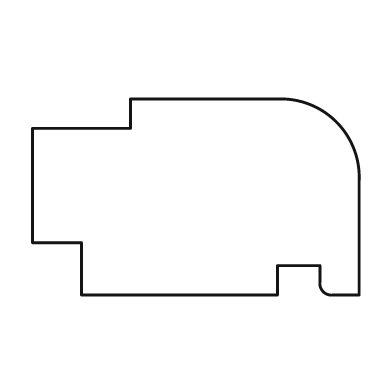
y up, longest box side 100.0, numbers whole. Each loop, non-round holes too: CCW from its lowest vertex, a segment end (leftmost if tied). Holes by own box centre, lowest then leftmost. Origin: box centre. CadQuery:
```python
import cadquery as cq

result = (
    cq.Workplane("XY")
    .moveTo(-35.0, -30.0)
    .lineTo(25.0, -30.0)
    .lineTo(25.0, -21.0)
    .lineTo(38.0, -21.0)
    .lineTo(38.0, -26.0)
    .threePointArc((39.0, -29.0), (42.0, -30.0))
    .lineTo(50.0, -30.0)
    .lineTo(50.0, 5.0)
    .threePointArc((43.0, 23.0), (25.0, 30.0))
    .lineTo(-20.0, 30.0)
    .lineTo(-20.0, 21.0)
    .lineTo(-50.0, 21.0)
    .lineTo(-50.0, -14.0)
    .lineTo(-35.0, -14.0)
    .close()
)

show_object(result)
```